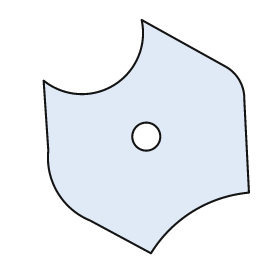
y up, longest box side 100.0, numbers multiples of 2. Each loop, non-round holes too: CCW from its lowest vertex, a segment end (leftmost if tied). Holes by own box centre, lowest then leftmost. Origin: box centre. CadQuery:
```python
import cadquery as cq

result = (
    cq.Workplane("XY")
    .moveTo(2.0, -50.0)
    .threePointArc((20.0, -32.0), (44.0, -24.0))
    .lineTo(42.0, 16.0)
    .threePointArc((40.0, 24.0), (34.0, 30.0))
    .lineTo(-2.0, 50.0)
    .threePointArc((-14.0, 22.0), (-44.0, 24.0))
    .lineTo(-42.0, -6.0)
    .threePointArc((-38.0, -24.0), (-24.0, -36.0))
    .close()
    .moveTo(0.0, 0.0)
    .circle(6.0)
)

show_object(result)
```